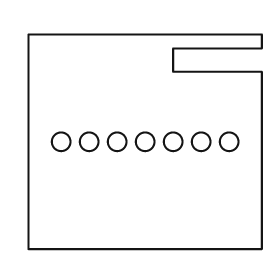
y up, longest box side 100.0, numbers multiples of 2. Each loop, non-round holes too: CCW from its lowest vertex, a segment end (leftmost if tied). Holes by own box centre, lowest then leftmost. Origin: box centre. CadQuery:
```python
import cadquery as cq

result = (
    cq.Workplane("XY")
    .moveTo(-50.0, -46.0)
    .lineTo(50.0, -46.0)
    .lineTo(50.0, 30.0)
    .lineTo(12.0, 30.0)
    .lineTo(12.0, 40.0)
    .lineTo(50.0, 40.0)
    .lineTo(50.0, 46.0)
    .lineTo(-50.0, 46.0)
    .close()
    .moveTo(-36.0, 0.0)
    .circle(4.0)
    .moveTo(-24.0, 0.0)
    .circle(4.0)
    .moveTo(-12.0, 0.0)
    .circle(4.0)
    .moveTo(0.0, 0.0)
    .circle(4.0)
    .moveTo(12.0, 0.0)
    .circle(4.0)
    .moveTo(24.0, 0.0)
    .circle(4.0)
    .moveTo(36.0, 0.0)
    .circle(4.0)
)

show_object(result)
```